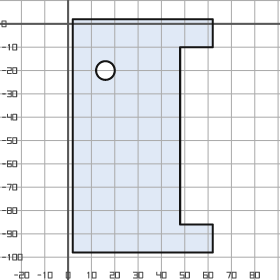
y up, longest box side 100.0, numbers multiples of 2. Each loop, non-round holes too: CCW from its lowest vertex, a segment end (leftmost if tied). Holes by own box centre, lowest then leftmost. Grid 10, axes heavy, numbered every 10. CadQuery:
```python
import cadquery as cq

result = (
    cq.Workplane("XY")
    .moveTo(2.0, -98.0)
    .lineTo(62.0, -98.0)
    .lineTo(62.0, -86.0)
    .lineTo(48.0, -86.0)
    .lineTo(48.0, -10.0)
    .lineTo(62.0, -10.0)
    .lineTo(62.0, 2.0)
    .lineTo(2.0, 2.0)
    .close()
    .moveTo(16.0, -20.0)
    .circle(4.0)
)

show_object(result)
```